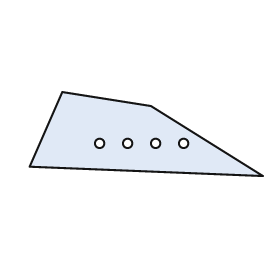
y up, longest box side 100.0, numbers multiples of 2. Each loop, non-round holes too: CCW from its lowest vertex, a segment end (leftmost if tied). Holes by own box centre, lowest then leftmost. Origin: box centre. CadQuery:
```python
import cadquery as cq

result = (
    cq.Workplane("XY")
    .moveTo(50.0, -18.0)
    .lineTo(2.0, 12.0)
    .lineTo(-36.0, 18.0)
    .lineTo(-50.0, -14.0)
    .close()
    .moveTo(-20.0, -4.0)
    .circle(2.0)
    .moveTo(-8.0, -4.0)
    .circle(2.0)
    .moveTo(4.0, -4.0)
    .circle(2.0)
    .moveTo(16.0, -4.0)
    .circle(2.0)
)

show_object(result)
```